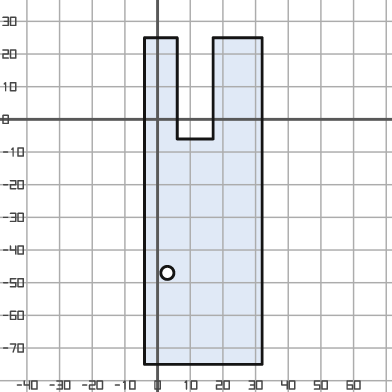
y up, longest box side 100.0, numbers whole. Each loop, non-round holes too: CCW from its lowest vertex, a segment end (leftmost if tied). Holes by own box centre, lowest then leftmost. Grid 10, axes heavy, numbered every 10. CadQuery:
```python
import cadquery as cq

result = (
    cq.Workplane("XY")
    .moveTo(-4.0, -75.0)
    .lineTo(32.0, -75.0)
    .lineTo(32.0, 25.0)
    .lineTo(17.0, 25.0)
    .lineTo(17.0, -6.0)
    .lineTo(6.0, -6.0)
    .lineTo(6.0, 25.0)
    .lineTo(-4.0, 25.0)
    .close()
    .moveTo(3.0, -47.0)
    .circle(2.0)
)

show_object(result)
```